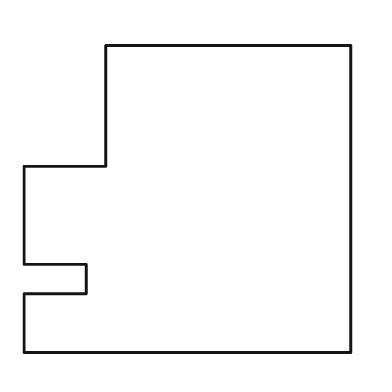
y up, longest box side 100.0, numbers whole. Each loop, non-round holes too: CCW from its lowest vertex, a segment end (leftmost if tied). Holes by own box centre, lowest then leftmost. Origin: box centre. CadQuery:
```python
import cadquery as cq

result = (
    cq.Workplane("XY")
    .moveTo(-50.0, -47.0)
    .lineTo(50.0, -47.0)
    .lineTo(50.0, 47.0)
    .lineTo(-25.0, 47.0)
    .lineTo(-25.0, 10.0)
    .lineTo(-50.0, 10.0)
    .lineTo(-50.0, -20.0)
    .lineTo(-31.0, -20.0)
    .lineTo(-31.0, -29.0)
    .lineTo(-50.0, -29.0)
    .close()
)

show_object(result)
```